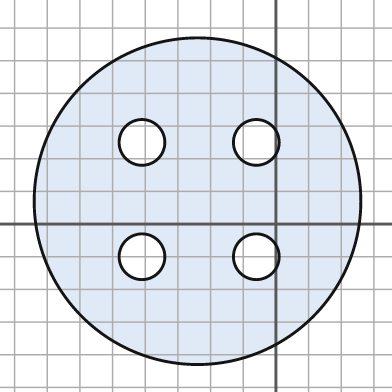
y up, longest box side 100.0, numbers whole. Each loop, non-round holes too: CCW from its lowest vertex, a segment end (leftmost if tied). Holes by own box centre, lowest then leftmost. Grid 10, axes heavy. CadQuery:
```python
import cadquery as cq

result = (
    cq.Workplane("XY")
    .moveTo(-24.0, 7.0)
    .circle(50.0)
    .moveTo(-41.0, -10.0)
    .circle(7.0)
    .moveTo(-6.0, -10.0)
    .circle(7.0)
    .moveTo(-41.0, 25.0)
    .circle(7.0)
    .moveTo(-6.0, 25.0)
    .circle(7.0)
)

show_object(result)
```